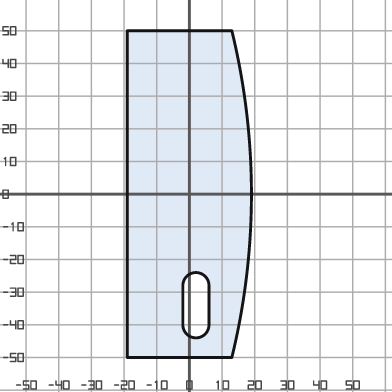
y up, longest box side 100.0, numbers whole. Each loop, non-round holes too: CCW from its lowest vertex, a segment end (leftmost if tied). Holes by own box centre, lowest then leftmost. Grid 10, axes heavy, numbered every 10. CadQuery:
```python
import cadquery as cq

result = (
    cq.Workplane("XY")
    .moveTo(-19.0, -50.0)
    .lineTo(13.0, -50.0)
    .threePointArc((19.0, 0.0), (13.0, 50.0))
    .lineTo(-19.0, 50.0)
    .close()
    .moveTo(-2.0, -40.0)
    .threePointArc((2.0, -44.0), (6.0, -40.0))
    .lineTo(6.0, -28.0)
    .threePointArc((2.0, -24.0), (-2.0, -28.0))
    .close()
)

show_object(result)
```